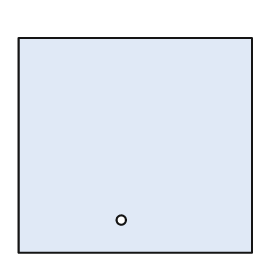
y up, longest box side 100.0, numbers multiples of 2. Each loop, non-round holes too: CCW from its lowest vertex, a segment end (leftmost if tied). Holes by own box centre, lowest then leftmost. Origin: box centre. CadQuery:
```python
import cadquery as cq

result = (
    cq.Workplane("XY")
    .moveTo(-50.0, -46.0)
    .lineTo(50.0, -46.0)
    .lineTo(50.0, 46.0)
    .lineTo(-50.0, 46.0)
    .close()
    .moveTo(-6.0, -32.0)
    .circle(2.0)
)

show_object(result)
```